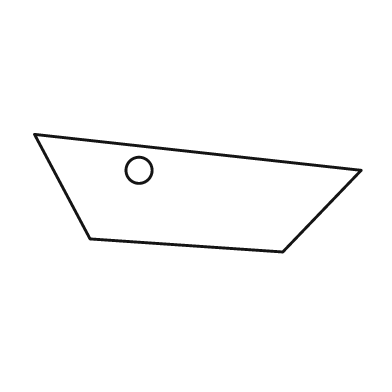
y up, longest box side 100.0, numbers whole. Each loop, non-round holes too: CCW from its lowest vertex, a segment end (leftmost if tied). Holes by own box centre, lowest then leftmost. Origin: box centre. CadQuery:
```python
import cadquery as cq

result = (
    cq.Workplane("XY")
    .moveTo(26.0, -18.0)
    .lineTo(50.0, 7.0)
    .lineTo(-50.0, 18.0)
    .lineTo(-33.0, -14.0)
    .close()
    .moveTo(-18.0, 7.0)
    .circle(4.0)
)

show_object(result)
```